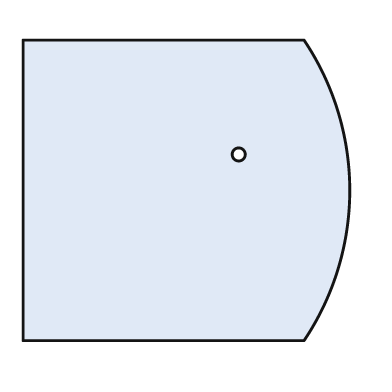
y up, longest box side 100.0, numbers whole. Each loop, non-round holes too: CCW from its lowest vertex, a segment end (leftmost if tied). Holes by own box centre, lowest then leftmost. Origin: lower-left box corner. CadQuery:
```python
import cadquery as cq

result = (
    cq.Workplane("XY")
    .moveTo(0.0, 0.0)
    .lineTo(86.0, 0.0)
    .threePointArc((100.0, 46.0), (86.0, 92.0))
    .lineTo(0.0, 92.0)
    .close()
    .moveTo(66.0, 57.0)
    .circle(2.0)
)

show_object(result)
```